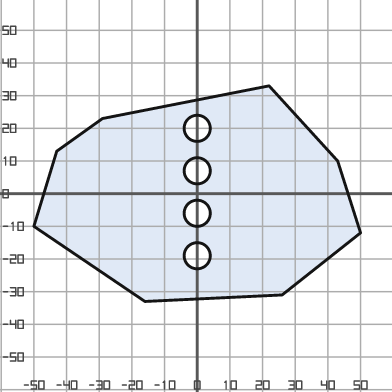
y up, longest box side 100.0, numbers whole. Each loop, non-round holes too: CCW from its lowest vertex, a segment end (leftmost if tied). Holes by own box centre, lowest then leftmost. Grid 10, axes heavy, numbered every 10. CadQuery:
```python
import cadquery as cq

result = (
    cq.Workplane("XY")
    .moveTo(-16.0, -33.0)
    .lineTo(26.0, -31.0)
    .lineTo(50.0, -12.0)
    .lineTo(43.0, 10.0)
    .lineTo(22.0, 33.0)
    .lineTo(-29.0, 23.0)
    .lineTo(-43.0, 13.0)
    .lineTo(-50.0, -10.0)
    .close()
    .moveTo(0.0, -19.0)
    .circle(4.0)
    .moveTo(0.0, -6.0)
    .circle(4.0)
    .moveTo(0.0, 7.0)
    .circle(4.0)
    .moveTo(0.0, 20.0)
    .circle(4.0)
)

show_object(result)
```